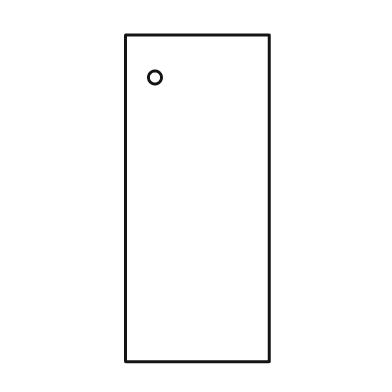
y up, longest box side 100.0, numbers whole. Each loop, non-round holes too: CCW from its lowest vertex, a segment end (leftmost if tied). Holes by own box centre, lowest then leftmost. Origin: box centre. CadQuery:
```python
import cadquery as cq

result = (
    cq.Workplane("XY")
    .moveTo(-22.0, -50.0)
    .lineTo(22.0, -50.0)
    .lineTo(22.0, 50.0)
    .lineTo(-22.0, 50.0)
    .close()
    .moveTo(-13.0, 37.0)
    .circle(2.0)
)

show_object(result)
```